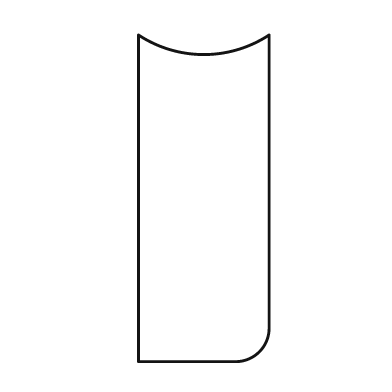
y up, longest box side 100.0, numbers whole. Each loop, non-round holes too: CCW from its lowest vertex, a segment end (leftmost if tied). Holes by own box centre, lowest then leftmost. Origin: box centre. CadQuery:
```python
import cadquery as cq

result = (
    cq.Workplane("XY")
    .moveTo(-20.0, -50.0)
    .lineTo(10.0, -50.0)
    .threePointArc((17.0, -47.0), (20.0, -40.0))
    .lineTo(20.0, 50.0)
    .threePointArc((0.0, 44.0), (-20.0, 50.0))
    .close()
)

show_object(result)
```